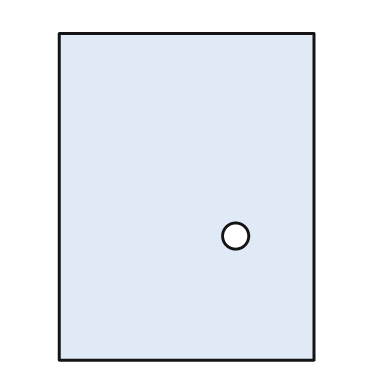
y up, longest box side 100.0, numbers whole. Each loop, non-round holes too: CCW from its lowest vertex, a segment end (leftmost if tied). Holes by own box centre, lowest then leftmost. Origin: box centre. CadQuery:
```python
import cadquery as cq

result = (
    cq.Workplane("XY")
    .moveTo(-39.0, -50.0)
    .lineTo(39.0, -50.0)
    .lineTo(39.0, 50.0)
    .lineTo(-39.0, 50.0)
    .close()
    .moveTo(15.0, -12.0)
    .circle(4.0)
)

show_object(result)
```